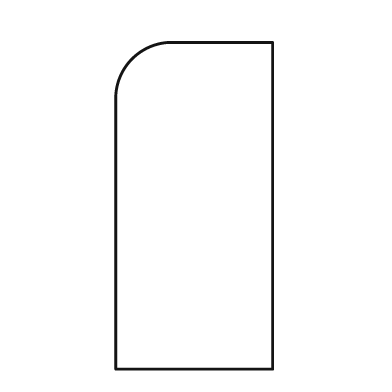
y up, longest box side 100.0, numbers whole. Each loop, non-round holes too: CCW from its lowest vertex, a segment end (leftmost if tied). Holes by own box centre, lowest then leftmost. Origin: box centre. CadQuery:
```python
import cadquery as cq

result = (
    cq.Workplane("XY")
    .moveTo(-24.0, -50.0)
    .lineTo(24.0, -50.0)
    .lineTo(24.0, 50.0)
    .lineTo(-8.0, 50.0)
    .threePointArc((-19.0, 45.0), (-24.0, 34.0))
    .close()
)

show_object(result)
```